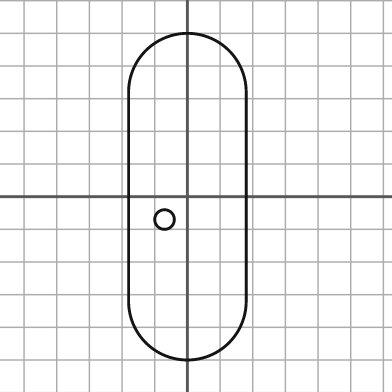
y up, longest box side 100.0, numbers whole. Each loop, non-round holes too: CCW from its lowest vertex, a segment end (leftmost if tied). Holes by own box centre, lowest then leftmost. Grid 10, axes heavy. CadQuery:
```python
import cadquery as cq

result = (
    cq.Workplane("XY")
    .moveTo(-18.0, -32.0)
    .threePointArc((0.0, -50.0), (18.0, -32.0))
    .lineTo(18.0, 32.0)
    .threePointArc((0.0, 50.0), (-18.0, 32.0))
    .close()
    .moveTo(-7.0, -7.0)
    .circle(3.0)
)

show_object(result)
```